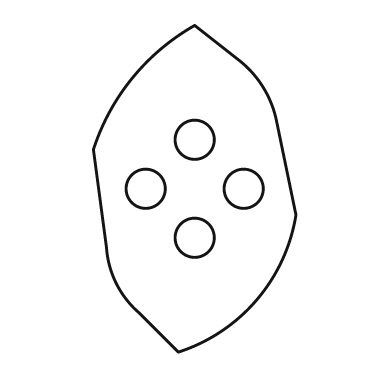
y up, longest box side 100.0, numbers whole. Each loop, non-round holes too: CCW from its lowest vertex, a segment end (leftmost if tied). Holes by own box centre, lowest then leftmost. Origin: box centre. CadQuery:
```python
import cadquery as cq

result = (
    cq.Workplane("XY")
    .moveTo(-5.0, -50.0)
    .threePointArc((19.0, -34.0), (31.0, -8.0))
    .lineTo(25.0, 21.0)
    .threePointArc((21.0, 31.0), (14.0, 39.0))
    .lineTo(0.0, 50.0)
    .threePointArc((-19.0, 34.0), (-31.0, 12.0))
    .lineTo(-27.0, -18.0)
    .threePointArc((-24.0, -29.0), (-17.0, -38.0))
    .close()
    .moveTo(0.0, -15.0)
    .circle(6.0)
    .moveTo(-15.0, 0.0)
    .circle(6.0)
    .moveTo(15.0, 0.0)
    .circle(6.0)
    .moveTo(0.0, 15.0)
    .circle(6.0)
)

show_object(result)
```